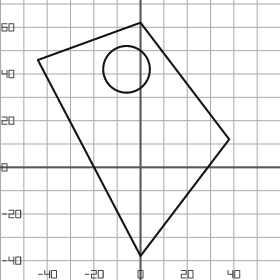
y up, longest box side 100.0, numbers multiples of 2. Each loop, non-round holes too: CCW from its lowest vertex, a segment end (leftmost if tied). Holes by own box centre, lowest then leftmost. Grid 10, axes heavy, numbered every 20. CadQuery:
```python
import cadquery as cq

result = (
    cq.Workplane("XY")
    .moveTo(0.0, -38.0)
    .lineTo(38.0, 12.0)
    .lineTo(0.0, 62.0)
    .lineTo(-44.0, 46.0)
    .close()
    .moveTo(-6.0, 42.0)
    .circle(10.0)
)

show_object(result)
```